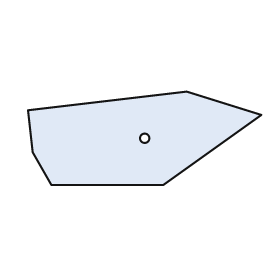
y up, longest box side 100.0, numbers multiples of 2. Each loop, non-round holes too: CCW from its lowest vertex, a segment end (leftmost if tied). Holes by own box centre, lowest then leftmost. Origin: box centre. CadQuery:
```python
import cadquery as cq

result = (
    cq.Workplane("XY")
    .moveTo(-40.0, -20.0)
    .lineTo(8.0, -20.0)
    .lineTo(50.0, 10.0)
    .lineTo(18.0, 20.0)
    .lineTo(-50.0, 12.0)
    .lineTo(-48.0, -6.0)
    .close()
    .moveTo(0.0, 0.0)
    .circle(2.0)
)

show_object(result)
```